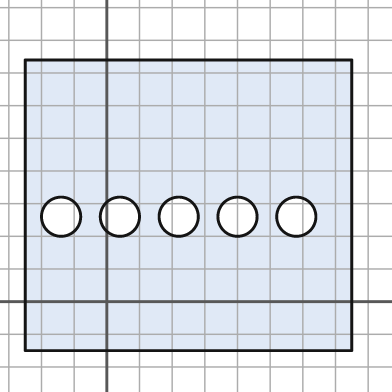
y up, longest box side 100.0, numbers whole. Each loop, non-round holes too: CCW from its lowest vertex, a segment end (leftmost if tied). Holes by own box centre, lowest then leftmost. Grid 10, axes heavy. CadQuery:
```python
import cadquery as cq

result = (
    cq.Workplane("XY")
    .moveTo(-25.0, -15.0)
    .lineTo(75.0, -15.0)
    .lineTo(75.0, 74.0)
    .lineTo(-25.0, 74.0)
    .close()
    .moveTo(-14.0, 26.0)
    .circle(6.0)
    .moveTo(4.0, 26.0)
    .circle(6.0)
    .moveTo(22.0, 26.0)
    .circle(6.0)
    .moveTo(40.0, 26.0)
    .circle(6.0)
    .moveTo(58.0, 26.0)
    .circle(6.0)
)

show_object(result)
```